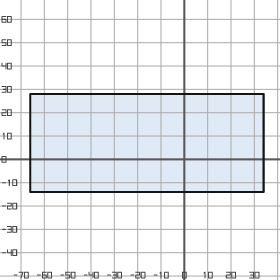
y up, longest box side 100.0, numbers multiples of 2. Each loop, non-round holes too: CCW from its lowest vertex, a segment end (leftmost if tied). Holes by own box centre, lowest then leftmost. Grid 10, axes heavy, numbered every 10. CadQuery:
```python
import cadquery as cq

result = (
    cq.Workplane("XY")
    .moveTo(-66.0, -14.0)
    .lineTo(34.0, -14.0)
    .lineTo(34.0, 28.0)
    .lineTo(-66.0, 28.0)
    .close()
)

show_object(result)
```